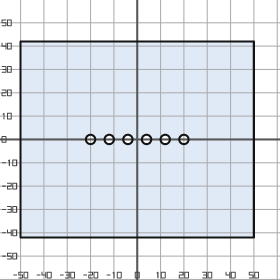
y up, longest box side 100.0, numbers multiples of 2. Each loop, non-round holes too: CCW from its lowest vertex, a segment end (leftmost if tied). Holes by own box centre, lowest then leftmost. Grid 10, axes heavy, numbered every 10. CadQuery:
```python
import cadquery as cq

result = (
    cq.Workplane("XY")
    .moveTo(-50.0, -42.0)
    .lineTo(50.0, -42.0)
    .lineTo(50.0, 42.0)
    .lineTo(-50.0, 42.0)
    .close()
    .moveTo(-20.0, 0.0)
    .circle(2.0)
    .moveTo(-12.0, 0.0)
    .circle(2.0)
    .moveTo(-4.0, 0.0)
    .circle(2.0)
    .moveTo(4.0, 0.0)
    .circle(2.0)
    .moveTo(12.0, 0.0)
    .circle(2.0)
    .moveTo(20.0, 0.0)
    .circle(2.0)
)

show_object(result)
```